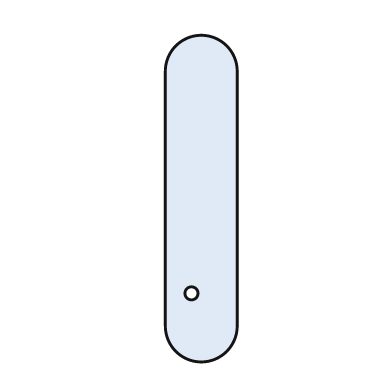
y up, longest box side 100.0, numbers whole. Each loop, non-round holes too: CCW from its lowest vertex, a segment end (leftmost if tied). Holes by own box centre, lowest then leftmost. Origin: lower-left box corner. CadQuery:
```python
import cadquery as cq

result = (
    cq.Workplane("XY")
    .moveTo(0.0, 11.0)
    .threePointArc((11.0, 0.0), (22.0, 11.0))
    .lineTo(22.0, 89.0)
    .threePointArc((11.0, 100.0), (0.0, 89.0))
    .close()
    .moveTo(8.0, 21.0)
    .circle(2.0)
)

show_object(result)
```